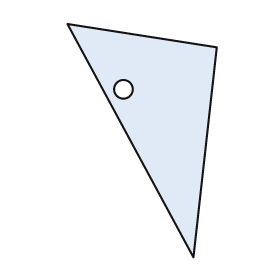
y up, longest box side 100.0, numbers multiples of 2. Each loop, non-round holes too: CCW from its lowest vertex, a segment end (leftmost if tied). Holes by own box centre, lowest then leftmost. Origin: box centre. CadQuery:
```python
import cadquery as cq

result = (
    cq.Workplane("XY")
    .moveTo(22.0, -50.0)
    .lineTo(32.0, 40.0)
    .lineTo(-32.0, 50.0)
    .close()
    .moveTo(-8.0, 22.0)
    .circle(4.0)
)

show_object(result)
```